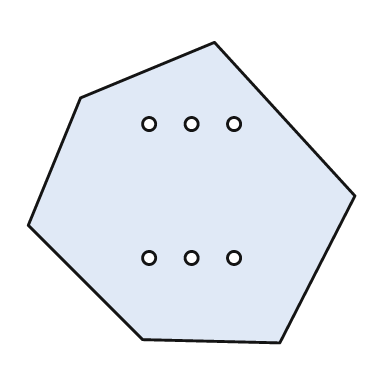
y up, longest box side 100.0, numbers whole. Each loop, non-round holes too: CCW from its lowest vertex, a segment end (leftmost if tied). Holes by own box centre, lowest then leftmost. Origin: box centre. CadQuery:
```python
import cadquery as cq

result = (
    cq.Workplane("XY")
    .moveTo(27.0, -46.0)
    .lineTo(50.0, -1.0)
    .lineTo(7.0, 46.0)
    .lineTo(-34.0, 29.0)
    .lineTo(-50.0, -10.0)
    .lineTo(-15.0, -45.0)
    .close()
    .moveTo(-13.0, -20.0)
    .circle(2.0)
    .moveTo(0.0, -20.0)
    .circle(2.0)
    .moveTo(13.0, -20.0)
    .circle(2.0)
    .moveTo(-13.0, 21.0)
    .circle(2.0)
    .moveTo(0.0, 21.0)
    .circle(2.0)
    .moveTo(13.0, 21.0)
    .circle(2.0)
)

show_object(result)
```